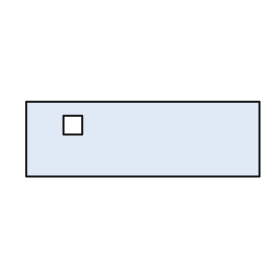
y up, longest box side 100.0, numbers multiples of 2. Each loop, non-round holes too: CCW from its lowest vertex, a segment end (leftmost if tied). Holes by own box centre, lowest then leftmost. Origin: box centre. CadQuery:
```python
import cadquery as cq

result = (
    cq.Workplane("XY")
    .moveTo(-50.0, -16.0)
    .lineTo(50.0, -16.0)
    .lineTo(50.0, 16.0)
    .lineTo(-50.0, 16.0)
    .close()
    .moveTo(-34.0, 2.0)
    .lineTo(-26.0, 2.0)
    .lineTo(-26.0, 10.0)
    .lineTo(-34.0, 10.0)
    .close()
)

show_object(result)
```